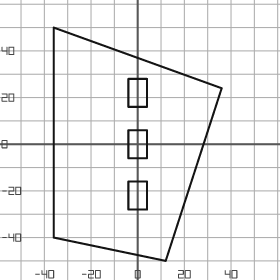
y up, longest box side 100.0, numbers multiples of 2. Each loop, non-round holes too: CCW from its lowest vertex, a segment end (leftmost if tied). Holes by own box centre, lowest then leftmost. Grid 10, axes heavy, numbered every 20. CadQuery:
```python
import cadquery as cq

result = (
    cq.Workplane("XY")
    .moveTo(12.0, -50.0)
    .lineTo(36.0, 24.0)
    .lineTo(-36.0, 50.0)
    .lineTo(-36.0, -40.0)
    .close()
    .moveTo(-4.0, -28.0)
    .lineTo(4.0, -28.0)
    .lineTo(4.0, -16.0)
    .lineTo(-4.0, -16.0)
    .close()
    .moveTo(-4.0, -6.0)
    .lineTo(4.0, -6.0)
    .lineTo(4.0, 6.0)
    .lineTo(-4.0, 6.0)
    .close()
    .moveTo(-4.0, 16.0)
    .lineTo(4.0, 16.0)
    .lineTo(4.0, 28.0)
    .lineTo(-4.0, 28.0)
    .close()
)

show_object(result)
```